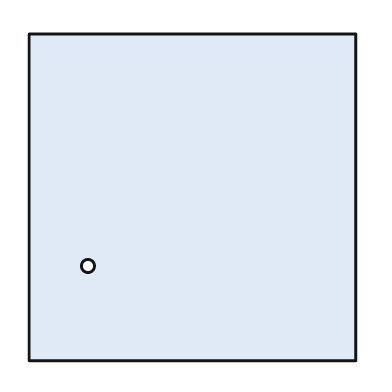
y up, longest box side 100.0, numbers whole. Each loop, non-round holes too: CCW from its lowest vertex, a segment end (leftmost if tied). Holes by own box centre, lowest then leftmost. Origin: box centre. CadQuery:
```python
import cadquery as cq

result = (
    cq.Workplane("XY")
    .moveTo(-50.0, -50.0)
    .lineTo(50.0, -50.0)
    .lineTo(50.0, 50.0)
    .lineTo(-50.0, 50.0)
    .close()
    .moveTo(-32.0, -21.0)
    .circle(2.0)
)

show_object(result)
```